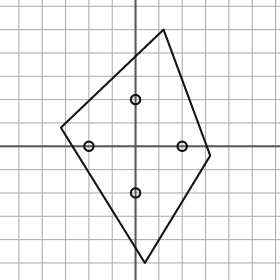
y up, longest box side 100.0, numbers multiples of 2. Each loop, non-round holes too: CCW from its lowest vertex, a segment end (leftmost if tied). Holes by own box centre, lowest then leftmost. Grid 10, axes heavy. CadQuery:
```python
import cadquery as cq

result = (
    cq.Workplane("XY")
    .moveTo(4.0, -50.0)
    .lineTo(32.0, -4.0)
    .lineTo(12.0, 50.0)
    .lineTo(-32.0, 8.0)
    .close()
    .moveTo(0.0, -20.0)
    .circle(2.0)
    .moveTo(-20.0, 0.0)
    .circle(2.0)
    .moveTo(20.0, 0.0)
    .circle(2.0)
    .moveTo(0.0, 20.0)
    .circle(2.0)
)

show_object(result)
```